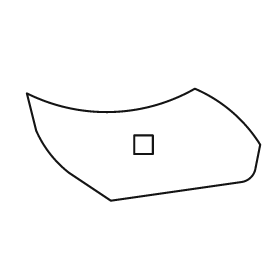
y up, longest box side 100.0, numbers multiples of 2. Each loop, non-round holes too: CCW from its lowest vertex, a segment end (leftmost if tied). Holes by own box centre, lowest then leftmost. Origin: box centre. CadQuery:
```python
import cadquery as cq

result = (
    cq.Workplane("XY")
    .moveTo(-14.0, -24.0)
    .lineTo(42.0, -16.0)
    .threePointArc((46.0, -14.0), (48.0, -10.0))
    .lineTo(50.0, 0.0)
    .threePointArc((38.0, 14.0), (22.0, 24.0))
    .threePointArc((-14.0, 14.0), (-50.0, 22.0))
    .lineTo(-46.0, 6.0)
    .threePointArc((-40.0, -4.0), (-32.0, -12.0))
    .close()
    .moveTo(-4.0, -4.0)
    .lineTo(4.0, -4.0)
    .lineTo(4.0, 4.0)
    .lineTo(-4.0, 4.0)
    .close()
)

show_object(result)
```